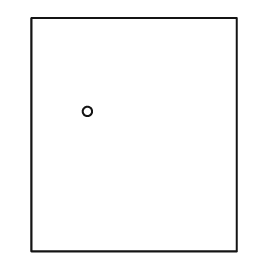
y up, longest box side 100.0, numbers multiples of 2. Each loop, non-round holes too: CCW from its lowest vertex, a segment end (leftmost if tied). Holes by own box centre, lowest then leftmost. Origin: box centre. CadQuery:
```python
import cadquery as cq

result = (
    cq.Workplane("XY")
    .moveTo(-44.0, -50.0)
    .lineTo(44.0, -50.0)
    .lineTo(44.0, 50.0)
    .lineTo(-44.0, 50.0)
    .close()
    .moveTo(-20.0, 10.0)
    .circle(2.0)
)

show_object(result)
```